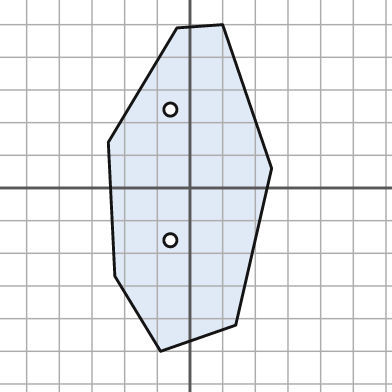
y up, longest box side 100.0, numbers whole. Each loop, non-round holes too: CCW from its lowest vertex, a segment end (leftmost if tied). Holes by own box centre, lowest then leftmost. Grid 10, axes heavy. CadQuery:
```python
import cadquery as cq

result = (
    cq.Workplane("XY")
    .moveTo(-9.0, -50.0)
    .lineTo(14.0, -42.0)
    .lineTo(25.0, 6.0)
    .lineTo(10.0, 50.0)
    .lineTo(-4.0, 49.0)
    .lineTo(-25.0, 14.0)
    .lineTo(-23.0, -27.0)
    .close()
    .moveTo(-6.0, -16.0)
    .circle(2.0)
    .moveTo(-6.0, 24.0)
    .circle(2.0)
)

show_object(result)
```